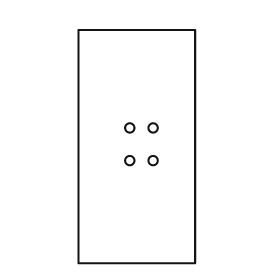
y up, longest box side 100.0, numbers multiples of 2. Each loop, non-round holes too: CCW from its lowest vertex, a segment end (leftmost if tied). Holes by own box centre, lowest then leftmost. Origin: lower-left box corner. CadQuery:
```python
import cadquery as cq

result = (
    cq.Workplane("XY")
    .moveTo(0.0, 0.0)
    .lineTo(50.0, 0.0)
    .lineTo(50.0, 100.0)
    .lineTo(0.0, 100.0)
    .close()
    .moveTo(22.0, 44.0)
    .circle(2.0)
    .moveTo(32.0, 44.0)
    .circle(2.0)
    .moveTo(22.0, 58.0)
    .circle(2.0)
    .moveTo(32.0, 58.0)
    .circle(2.0)
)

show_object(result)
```